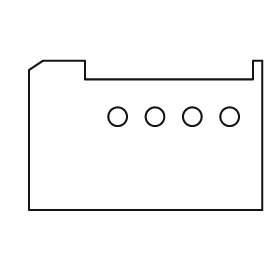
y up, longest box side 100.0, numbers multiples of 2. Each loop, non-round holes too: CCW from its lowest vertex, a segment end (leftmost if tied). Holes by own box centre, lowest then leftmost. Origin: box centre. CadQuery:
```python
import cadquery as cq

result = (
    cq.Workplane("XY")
    .moveTo(-50.0, -32.0)
    .lineTo(50.0, -32.0)
    .lineTo(50.0, 32.0)
    .lineTo(46.0, 32.0)
    .lineTo(46.0, 24.0)
    .lineTo(-26.0, 24.0)
    .lineTo(-26.0, 32.0)
    .lineTo(-44.0, 32.0)
    .lineTo(-50.0, 28.0)
    .close()
    .moveTo(-12.0, 8.0)
    .circle(4.0)
    .moveTo(4.0, 8.0)
    .circle(4.0)
    .moveTo(20.0, 8.0)
    .circle(4.0)
    .moveTo(36.0, 8.0)
    .circle(4.0)
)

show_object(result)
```